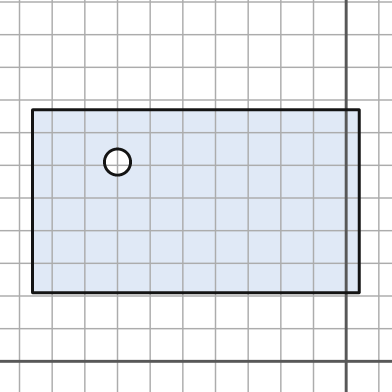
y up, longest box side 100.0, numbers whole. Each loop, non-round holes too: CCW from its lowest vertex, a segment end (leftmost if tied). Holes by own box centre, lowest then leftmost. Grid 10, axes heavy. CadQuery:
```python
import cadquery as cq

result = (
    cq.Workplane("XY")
    .moveTo(-96.0, 21.0)
    .lineTo(4.0, 21.0)
    .lineTo(4.0, 77.0)
    .lineTo(-96.0, 77.0)
    .close()
    .moveTo(-70.0, 61.0)
    .circle(4.0)
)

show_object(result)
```